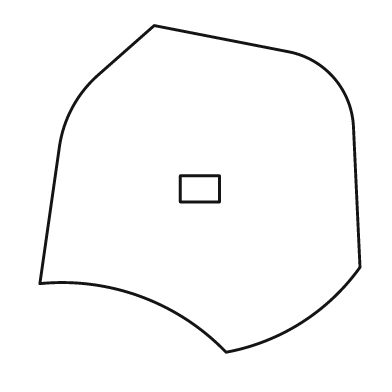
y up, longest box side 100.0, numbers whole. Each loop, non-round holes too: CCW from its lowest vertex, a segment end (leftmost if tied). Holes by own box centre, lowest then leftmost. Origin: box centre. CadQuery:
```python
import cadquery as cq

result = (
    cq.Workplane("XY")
    .moveTo(8.0, -50.0)
    .threePointArc((31.0, -41.0), (49.0, -24.0))
    .lineTo(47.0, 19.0)
    .threePointArc((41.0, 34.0), (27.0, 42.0))
    .lineTo(-14.0, 50.0)
    .lineTo(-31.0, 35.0)
    .threePointArc((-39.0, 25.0), (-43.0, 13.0))
    .lineTo(-49.0, -29.0)
    .threePointArc((-18.0, -33.0), (8.0, -50.0))
    .close()
    .moveTo(-6.0, -4.0)
    .lineTo(6.0, -4.0)
    .lineTo(6.0, 4.0)
    .lineTo(-6.0, 4.0)
    .close()
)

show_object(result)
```